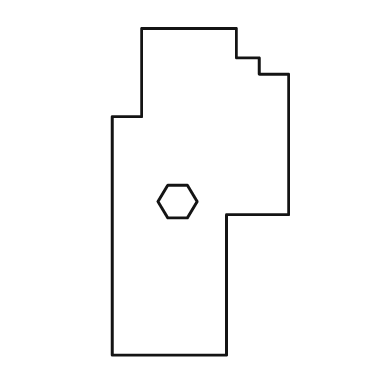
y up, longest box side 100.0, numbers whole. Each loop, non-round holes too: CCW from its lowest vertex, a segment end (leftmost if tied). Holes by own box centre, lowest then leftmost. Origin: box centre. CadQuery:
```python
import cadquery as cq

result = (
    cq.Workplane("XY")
    .moveTo(-27.0, -50.0)
    .lineTo(8.0, -50.0)
    .lineTo(8.0, -7.0)
    .lineTo(27.0, -7.0)
    .lineTo(27.0, 36.0)
    .lineTo(18.0, 36.0)
    .lineTo(18.0, 41.0)
    .lineTo(11.0, 41.0)
    .lineTo(11.0, 50.0)
    .lineTo(-18.0, 50.0)
    .lineTo(-18.0, 23.0)
    .lineTo(-27.0, 23.0)
    .close()
    .moveTo(-10.0, -8.0)
    .lineTo(-4.0, -8.0)
    .lineTo(-1.0, -3.0)
    .lineTo(-4.0, 2.0)
    .lineTo(-10.0, 2.0)
    .lineTo(-13.0, -3.0)
    .close()
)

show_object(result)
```